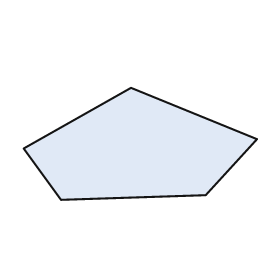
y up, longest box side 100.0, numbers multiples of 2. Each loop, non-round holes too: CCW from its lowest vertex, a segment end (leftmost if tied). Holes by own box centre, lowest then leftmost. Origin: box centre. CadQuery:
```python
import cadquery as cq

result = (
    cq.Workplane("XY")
    .moveTo(-34.0, -24.0)
    .lineTo(28.0, -22.0)
    .lineTo(50.0, 2.0)
    .lineTo(-4.0, 24.0)
    .lineTo(-50.0, -2.0)
    .close()
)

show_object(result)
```